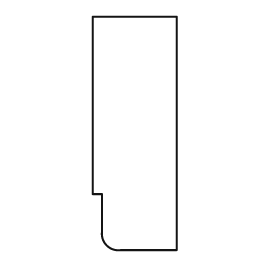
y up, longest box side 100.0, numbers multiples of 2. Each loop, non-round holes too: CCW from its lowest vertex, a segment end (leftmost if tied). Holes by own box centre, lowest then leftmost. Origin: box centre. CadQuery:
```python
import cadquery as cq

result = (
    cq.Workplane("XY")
    .moveTo(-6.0, -50.0)
    .lineTo(18.0, -50.0)
    .lineTo(18.0, 50.0)
    .lineTo(-18.0, 50.0)
    .lineTo(-18.0, -26.0)
    .lineTo(-14.0, -26.0)
    .lineTo(-14.0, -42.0)
    .threePointArc((-12.0, -48.0), (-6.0, -50.0))
    .close()
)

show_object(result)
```